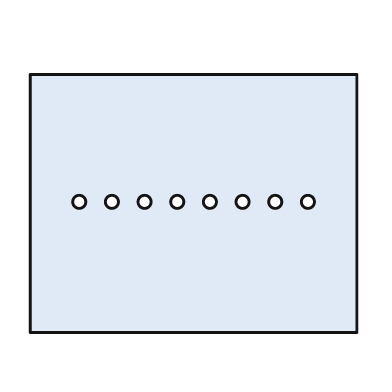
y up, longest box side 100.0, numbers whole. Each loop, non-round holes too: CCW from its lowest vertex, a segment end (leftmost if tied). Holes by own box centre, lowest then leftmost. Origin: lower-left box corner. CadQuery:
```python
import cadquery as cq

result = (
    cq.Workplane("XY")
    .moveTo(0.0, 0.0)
    .lineTo(100.0, 0.0)
    .lineTo(100.0, 79.0)
    .lineTo(0.0, 79.0)
    .close()
    .moveTo(15.0, 40.0)
    .circle(2.0)
    .moveTo(25.0, 40.0)
    .circle(2.0)
    .moveTo(35.0, 40.0)
    .circle(2.0)
    .moveTo(45.0, 40.0)
    .circle(2.0)
    .moveTo(55.0, 40.0)
    .circle(2.0)
    .moveTo(65.0, 40.0)
    .circle(2.0)
    .moveTo(75.0, 40.0)
    .circle(2.0)
    .moveTo(85.0, 40.0)
    .circle(2.0)
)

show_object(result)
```